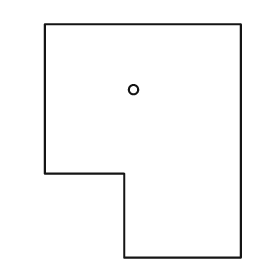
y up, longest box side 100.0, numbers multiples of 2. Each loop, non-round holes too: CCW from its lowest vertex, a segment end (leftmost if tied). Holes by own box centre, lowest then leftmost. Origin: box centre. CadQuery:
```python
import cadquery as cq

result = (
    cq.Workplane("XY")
    .moveTo(-8.0, -50.0)
    .lineTo(42.0, -50.0)
    .lineTo(42.0, 50.0)
    .lineTo(-42.0, 50.0)
    .lineTo(-42.0, -14.0)
    .lineTo(-8.0, -14.0)
    .close()
    .moveTo(-4.0, 22.0)
    .circle(2.0)
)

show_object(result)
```